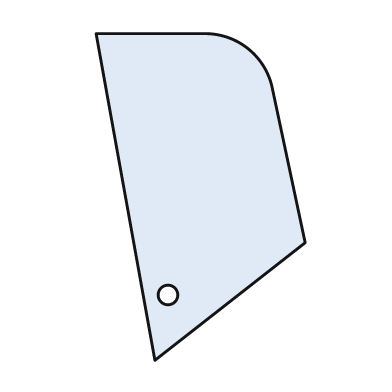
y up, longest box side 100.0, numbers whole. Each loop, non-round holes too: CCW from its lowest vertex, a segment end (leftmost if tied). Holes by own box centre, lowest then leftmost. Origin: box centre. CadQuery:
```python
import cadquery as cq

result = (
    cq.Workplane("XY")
    .moveTo(-14.0, -50.0)
    .lineTo(32.0, -14.0)
    .lineTo(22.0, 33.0)
    .threePointArc((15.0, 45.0), (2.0, 50.0))
    .lineTo(-32.0, 50.0)
    .close()
    .moveTo(-10.0, -30.0)
    .circle(3.0)
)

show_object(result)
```